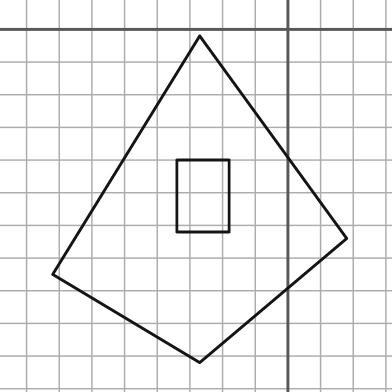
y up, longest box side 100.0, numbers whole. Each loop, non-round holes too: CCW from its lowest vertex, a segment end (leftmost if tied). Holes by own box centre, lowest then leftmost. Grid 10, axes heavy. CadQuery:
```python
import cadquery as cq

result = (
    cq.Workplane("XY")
    .moveTo(-27.0, -102.0)
    .lineTo(18.0, -64.0)
    .lineTo(-27.0, -2.0)
    .lineTo(-72.0, -75.0)
    .close()
    .moveTo(-34.0, -62.0)
    .lineTo(-18.0, -62.0)
    .lineTo(-18.0, -40.0)
    .lineTo(-34.0, -40.0)
    .close()
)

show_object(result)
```